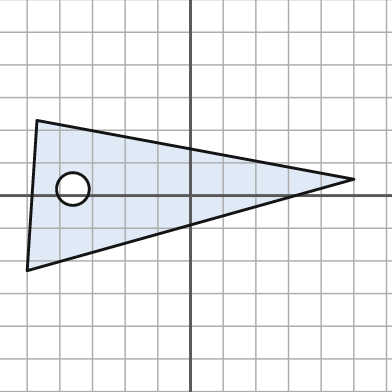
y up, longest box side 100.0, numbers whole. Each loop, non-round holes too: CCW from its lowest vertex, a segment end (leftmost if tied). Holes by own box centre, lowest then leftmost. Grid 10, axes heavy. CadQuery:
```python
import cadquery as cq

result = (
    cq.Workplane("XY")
    .moveTo(-50.0, -23.0)
    .lineTo(50.0, 5.0)
    .lineTo(-47.0, 23.0)
    .close()
    .moveTo(-36.0, 2.0)
    .circle(5.0)
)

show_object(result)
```